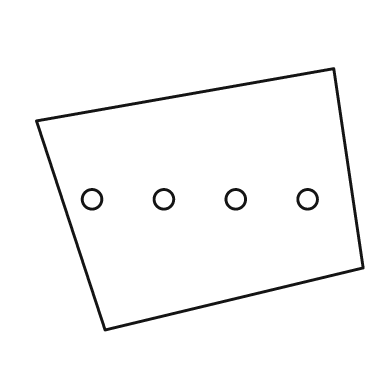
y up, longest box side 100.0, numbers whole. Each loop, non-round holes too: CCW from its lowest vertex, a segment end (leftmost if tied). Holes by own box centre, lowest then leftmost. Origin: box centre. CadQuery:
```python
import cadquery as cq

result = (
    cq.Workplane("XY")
    .moveTo(-29.0, -40.0)
    .lineTo(50.0, -21.0)
    .lineTo(41.0, 40.0)
    .lineTo(-50.0, 24.0)
    .close()
    .moveTo(-33.0, 0.0)
    .circle(3.0)
    .moveTo(-11.0, 0.0)
    .circle(3.0)
    .moveTo(11.0, 0.0)
    .circle(3.0)
    .moveTo(33.0, 0.0)
    .circle(3.0)
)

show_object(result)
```